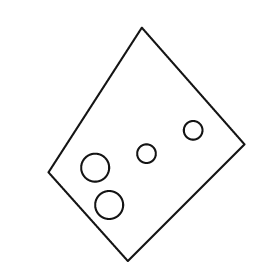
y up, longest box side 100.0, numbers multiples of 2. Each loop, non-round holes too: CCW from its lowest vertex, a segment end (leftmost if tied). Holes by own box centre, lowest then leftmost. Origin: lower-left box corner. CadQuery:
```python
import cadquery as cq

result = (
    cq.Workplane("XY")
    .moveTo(34.0, 0.0)
    .lineTo(84.0, 50.0)
    .lineTo(40.0, 100.0)
    .lineTo(0.0, 38.0)
    .close()
    .moveTo(26.0, 24.0)
    .circle(6.0)
    .moveTo(20.0, 40.0)
    .circle(6.0)
    .moveTo(42.0, 46.0)
    .circle(4.0)
    .moveTo(62.0, 56.0)
    .circle(4.0)
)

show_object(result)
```